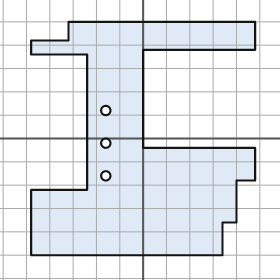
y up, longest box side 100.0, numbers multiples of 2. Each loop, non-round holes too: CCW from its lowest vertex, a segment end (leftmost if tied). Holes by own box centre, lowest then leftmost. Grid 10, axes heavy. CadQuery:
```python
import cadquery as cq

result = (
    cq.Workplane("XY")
    .moveTo(-48.0, -50.0)
    .lineTo(34.0, -50.0)
    .lineTo(34.0, -36.0)
    .lineTo(40.0, -36.0)
    .lineTo(40.0, -18.0)
    .lineTo(48.0, -18.0)
    .lineTo(48.0, -4.0)
    .lineTo(0.0, -4.0)
    .lineTo(0.0, 38.0)
    .lineTo(48.0, 38.0)
    .lineTo(48.0, 50.0)
    .lineTo(-32.0, 50.0)
    .lineTo(-32.0, 42.0)
    .lineTo(-48.0, 42.0)
    .lineTo(-48.0, 36.0)
    .lineTo(-24.0, 36.0)
    .lineTo(-24.0, -22.0)
    .lineTo(-48.0, -22.0)
    .close()
    .moveTo(-16.0, -16.0)
    .circle(2.0)
    .moveTo(-16.0, -2.0)
    .circle(2.0)
    .moveTo(-16.0, 12.0)
    .circle(2.0)
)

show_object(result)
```